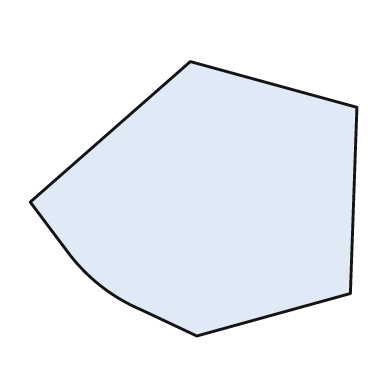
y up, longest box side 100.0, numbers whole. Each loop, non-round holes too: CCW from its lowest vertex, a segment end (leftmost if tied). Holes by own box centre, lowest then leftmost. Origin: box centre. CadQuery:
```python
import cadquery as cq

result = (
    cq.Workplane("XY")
    .moveTo(1.0, -42.0)
    .lineTo(48.0, -29.0)
    .lineTo(50.0, 28.0)
    .lineTo(-1.0, 42.0)
    .lineTo(-50.0, -1.0)
    .lineTo(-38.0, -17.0)
    .threePointArc((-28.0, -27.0), (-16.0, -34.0))
    .close()
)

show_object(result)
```